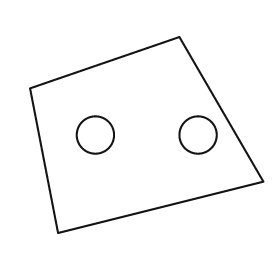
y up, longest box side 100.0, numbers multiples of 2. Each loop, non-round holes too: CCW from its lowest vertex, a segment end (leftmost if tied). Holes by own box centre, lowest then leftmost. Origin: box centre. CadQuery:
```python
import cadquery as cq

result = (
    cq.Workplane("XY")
    .moveTo(-38.0, -42.0)
    .lineTo(50.0, -20.0)
    .lineTo(14.0, 42.0)
    .lineTo(-50.0, 20.0)
    .close()
    .moveTo(-22.0, 0.0)
    .circle(8.0)
    .moveTo(22.0, 0.0)
    .circle(8.0)
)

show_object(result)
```